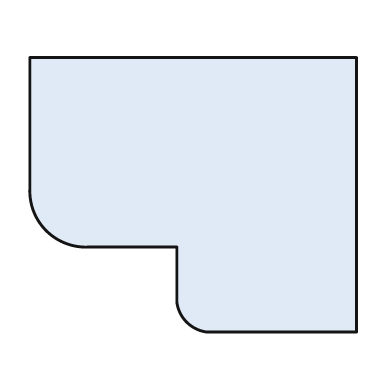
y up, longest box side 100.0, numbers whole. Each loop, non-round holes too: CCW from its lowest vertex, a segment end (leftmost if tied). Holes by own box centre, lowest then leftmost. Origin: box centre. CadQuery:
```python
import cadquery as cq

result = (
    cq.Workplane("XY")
    .moveTo(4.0, -42.0)
    .lineTo(50.0, -42.0)
    .lineTo(50.0, 42.0)
    .lineTo(-50.0, 42.0)
    .lineTo(-50.0, 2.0)
    .threePointArc((-45.0, -11.0), (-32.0, -16.0))
    .lineTo(-5.0, -16.0)
    .lineTo(-5.0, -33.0)
    .threePointArc((-2.0, -39.0), (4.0, -42.0))
    .close()
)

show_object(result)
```